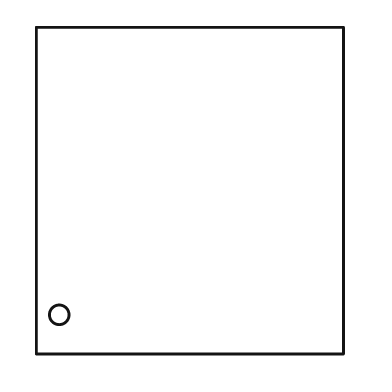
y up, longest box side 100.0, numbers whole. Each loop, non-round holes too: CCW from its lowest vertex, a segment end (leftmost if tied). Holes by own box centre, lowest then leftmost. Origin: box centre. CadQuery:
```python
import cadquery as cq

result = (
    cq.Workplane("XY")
    .moveTo(-47.0, -50.0)
    .lineTo(47.0, -50.0)
    .lineTo(47.0, 50.0)
    .lineTo(-47.0, 50.0)
    .close()
    .moveTo(-40.0, -38.0)
    .circle(3.0)
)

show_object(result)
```